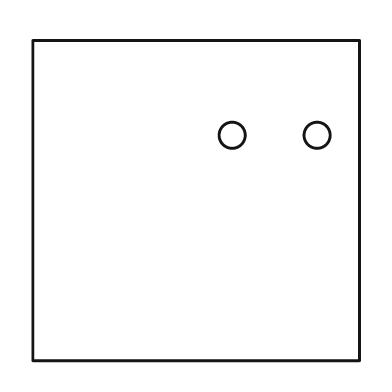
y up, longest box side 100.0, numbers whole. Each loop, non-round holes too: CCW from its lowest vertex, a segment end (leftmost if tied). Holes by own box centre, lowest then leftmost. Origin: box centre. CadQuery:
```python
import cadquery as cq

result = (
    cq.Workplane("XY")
    .moveTo(-50.0, -49.0)
    .lineTo(50.0, -49.0)
    .lineTo(50.0, 49.0)
    .lineTo(-50.0, 49.0)
    .close()
    .moveTo(11.0, 20.0)
    .circle(4.0)
    .moveTo(37.0, 20.0)
    .circle(4.0)
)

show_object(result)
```